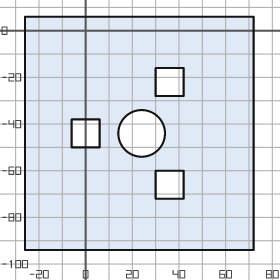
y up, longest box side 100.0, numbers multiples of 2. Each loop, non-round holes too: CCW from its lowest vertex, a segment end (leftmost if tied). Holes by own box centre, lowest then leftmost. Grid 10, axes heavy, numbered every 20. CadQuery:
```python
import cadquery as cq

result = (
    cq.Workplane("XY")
    .moveTo(-26.0, -94.0)
    .lineTo(72.0, -94.0)
    .lineTo(72.0, 6.0)
    .lineTo(-26.0, 6.0)
    .close()
    .moveTo(30.0, -72.0)
    .lineTo(42.0, -72.0)
    .lineTo(42.0, -60.0)
    .lineTo(30.0, -60.0)
    .close()
    .moveTo(-6.0, -50.0)
    .lineTo(6.0, -50.0)
    .lineTo(6.0, -38.0)
    .lineTo(-6.0, -38.0)
    .close()
    .moveTo(24.0, -44.0)
    .circle(10.0)
    .moveTo(30.0, -28.0)
    .lineTo(42.0, -28.0)
    .lineTo(42.0, -16.0)
    .lineTo(30.0, -16.0)
    .close()
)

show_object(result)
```